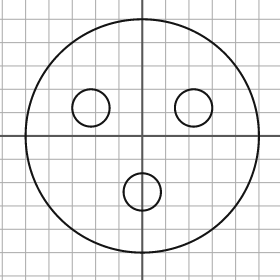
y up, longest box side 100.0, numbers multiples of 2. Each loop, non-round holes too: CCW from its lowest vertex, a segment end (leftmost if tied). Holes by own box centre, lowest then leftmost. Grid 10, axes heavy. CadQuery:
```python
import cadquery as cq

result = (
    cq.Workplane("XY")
    .moveTo(0.0, 0.0)
    .circle(50.0)
    .moveTo(0.0, -24.0)
    .circle(8.0)
    .moveTo(-22.0, 12.0)
    .circle(8.0)
    .moveTo(22.0, 12.0)
    .circle(8.0)
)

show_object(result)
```